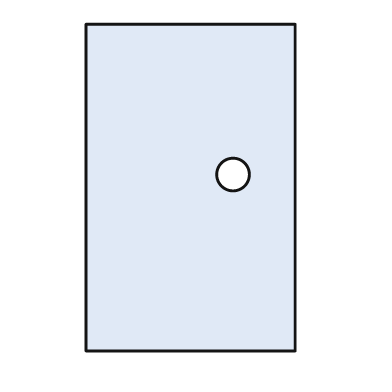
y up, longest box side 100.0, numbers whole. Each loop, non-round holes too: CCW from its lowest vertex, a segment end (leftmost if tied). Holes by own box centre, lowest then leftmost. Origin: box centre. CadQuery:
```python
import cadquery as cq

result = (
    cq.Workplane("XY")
    .moveTo(-32.0, -50.0)
    .lineTo(32.0, -50.0)
    .lineTo(32.0, 50.0)
    .lineTo(-32.0, 50.0)
    .close()
    .moveTo(13.0, 4.0)
    .circle(5.0)
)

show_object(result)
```